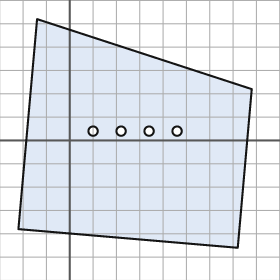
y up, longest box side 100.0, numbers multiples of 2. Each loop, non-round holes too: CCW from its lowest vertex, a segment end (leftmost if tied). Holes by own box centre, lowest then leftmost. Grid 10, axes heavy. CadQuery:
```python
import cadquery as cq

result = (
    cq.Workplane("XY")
    .moveTo(72.0, -46.0)
    .lineTo(78.0, 22.0)
    .lineTo(-14.0, 52.0)
    .lineTo(-22.0, -38.0)
    .close()
    .moveTo(10.0, 4.0)
    .circle(2.0)
    .moveTo(22.0, 4.0)
    .circle(2.0)
    .moveTo(34.0, 4.0)
    .circle(2.0)
    .moveTo(46.0, 4.0)
    .circle(2.0)
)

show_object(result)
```